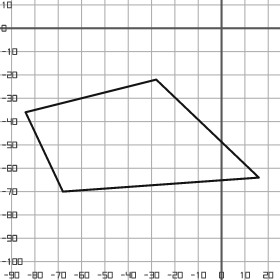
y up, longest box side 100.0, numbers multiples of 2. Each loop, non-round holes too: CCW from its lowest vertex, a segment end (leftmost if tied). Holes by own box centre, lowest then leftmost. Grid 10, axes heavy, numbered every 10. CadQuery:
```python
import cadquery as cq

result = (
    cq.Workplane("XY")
    .moveTo(-68.0, -70.0)
    .lineTo(16.0, -64.0)
    .lineTo(-28.0, -22.0)
    .lineTo(-84.0, -36.0)
    .close()
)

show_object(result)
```